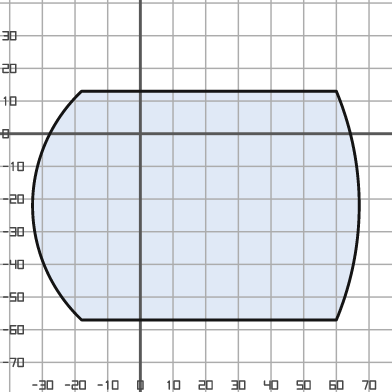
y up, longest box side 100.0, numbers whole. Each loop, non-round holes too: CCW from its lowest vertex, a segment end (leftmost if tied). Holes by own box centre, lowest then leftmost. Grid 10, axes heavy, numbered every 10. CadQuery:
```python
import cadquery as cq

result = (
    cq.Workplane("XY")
    .moveTo(-18.0, -57.0)
    .lineTo(60.0, -57.0)
    .threePointArc((67.0, -22.0), (60.0, 13.0))
    .lineTo(-18.0, 13.0)
    .threePointArc((-33.0, -22.0), (-18.0, -57.0))
    .close()
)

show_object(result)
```